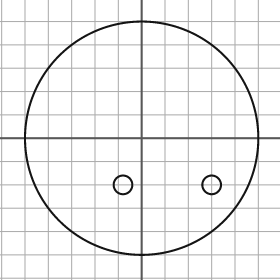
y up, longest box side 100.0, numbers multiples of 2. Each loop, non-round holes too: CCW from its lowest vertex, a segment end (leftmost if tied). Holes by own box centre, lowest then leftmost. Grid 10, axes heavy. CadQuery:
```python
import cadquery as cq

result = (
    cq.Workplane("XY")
    .moveTo(0.0, 0.0)
    .circle(50.0)
    .moveTo(-8.0, -20.0)
    .circle(4.0)
    .moveTo(30.0, -20.0)
    .circle(4.0)
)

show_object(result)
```